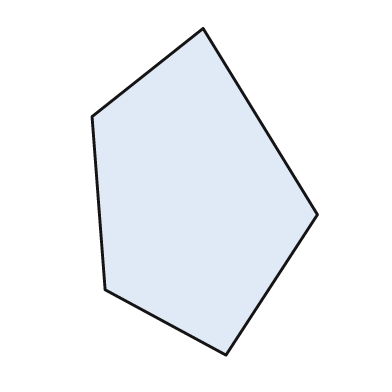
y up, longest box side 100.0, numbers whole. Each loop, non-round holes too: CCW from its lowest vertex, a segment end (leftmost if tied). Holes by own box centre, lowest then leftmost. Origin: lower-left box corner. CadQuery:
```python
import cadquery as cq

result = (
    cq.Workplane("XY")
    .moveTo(41.0, 0.0)
    .lineTo(69.0, 43.0)
    .lineTo(34.0, 100.0)
    .lineTo(0.0, 73.0)
    .lineTo(4.0, 20.0)
    .close()
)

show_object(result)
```